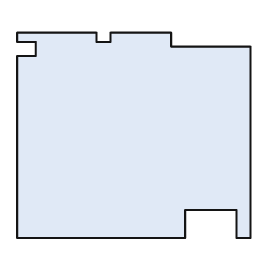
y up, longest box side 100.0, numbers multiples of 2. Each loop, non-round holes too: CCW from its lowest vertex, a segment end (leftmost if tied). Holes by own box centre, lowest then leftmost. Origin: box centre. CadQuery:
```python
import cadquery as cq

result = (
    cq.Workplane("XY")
    .moveTo(-50.0, -44.0)
    .lineTo(22.0, -44.0)
    .lineTo(22.0, -32.0)
    .lineTo(44.0, -32.0)
    .lineTo(44.0, -44.0)
    .lineTo(50.0, -44.0)
    .lineTo(50.0, 38.0)
    .lineTo(16.0, 38.0)
    .lineTo(16.0, 44.0)
    .lineTo(-10.0, 44.0)
    .lineTo(-10.0, 40.0)
    .lineTo(-16.0, 40.0)
    .lineTo(-16.0, 44.0)
    .lineTo(-50.0, 44.0)
    .lineTo(-50.0, 40.0)
    .lineTo(-42.0, 40.0)
    .lineTo(-42.0, 34.0)
    .lineTo(-50.0, 34.0)
    .close()
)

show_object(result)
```